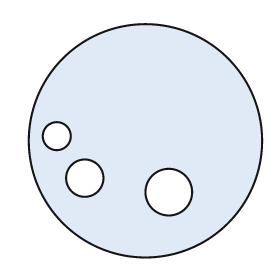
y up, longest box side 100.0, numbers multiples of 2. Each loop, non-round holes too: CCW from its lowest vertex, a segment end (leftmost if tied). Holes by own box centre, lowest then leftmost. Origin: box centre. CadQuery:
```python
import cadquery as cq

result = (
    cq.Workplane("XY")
    .moveTo(0.0, 0.0)
    .circle(50.0)
    .moveTo(10.0, -22.0)
    .circle(10.0)
    .moveTo(-26.0, -16.0)
    .circle(8.0)
    .moveTo(-38.0, 2.0)
    .circle(6.0)
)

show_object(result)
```